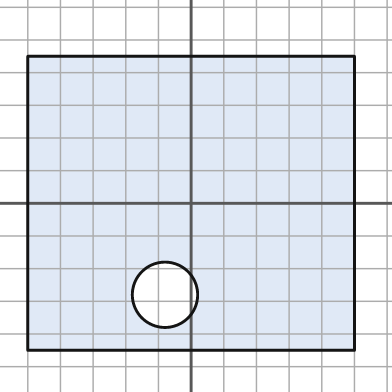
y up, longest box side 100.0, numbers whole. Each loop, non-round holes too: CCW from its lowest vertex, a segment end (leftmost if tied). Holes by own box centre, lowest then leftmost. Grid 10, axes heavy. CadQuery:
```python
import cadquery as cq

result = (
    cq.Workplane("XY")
    .moveTo(-50.0, -45.0)
    .lineTo(50.0, -45.0)
    .lineTo(50.0, 45.0)
    .lineTo(-50.0, 45.0)
    .close()
    .moveTo(-8.0, -28.0)
    .circle(10.0)
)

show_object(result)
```